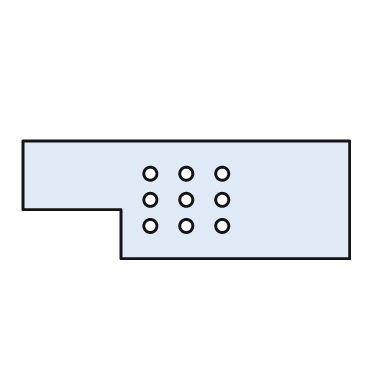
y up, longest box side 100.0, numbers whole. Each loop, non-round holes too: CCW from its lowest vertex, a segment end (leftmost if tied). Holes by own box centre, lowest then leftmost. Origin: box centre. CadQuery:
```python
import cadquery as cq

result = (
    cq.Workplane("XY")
    .moveTo(-20.0, -18.0)
    .lineTo(50.0, -18.0)
    .lineTo(50.0, 18.0)
    .lineTo(-50.0, 18.0)
    .lineTo(-50.0, -3.0)
    .lineTo(-20.0, -3.0)
    .close()
    .moveTo(-11.0, -8.0)
    .circle(2.0)
    .moveTo(0.0, -8.0)
    .circle(2.0)
    .moveTo(11.0, -8.0)
    .circle(2.0)
    .moveTo(-11.0, 0.0)
    .circle(2.0)
    .moveTo(0.0, 0.0)
    .circle(2.0)
    .moveTo(11.0, 0.0)
    .circle(2.0)
    .moveTo(-11.0, 8.0)
    .circle(2.0)
    .moveTo(0.0, 8.0)
    .circle(2.0)
    .moveTo(11.0, 8.0)
    .circle(2.0)
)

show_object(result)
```